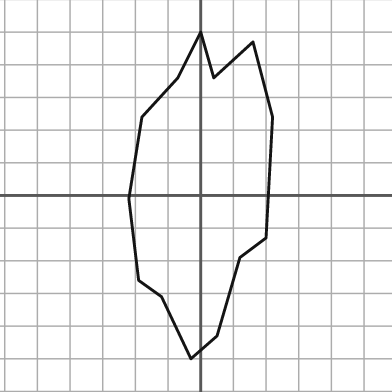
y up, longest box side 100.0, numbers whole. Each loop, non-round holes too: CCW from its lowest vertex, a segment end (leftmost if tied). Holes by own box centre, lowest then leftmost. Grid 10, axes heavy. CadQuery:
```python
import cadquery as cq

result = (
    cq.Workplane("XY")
    .moveTo(-3.0, -50.0)
    .lineTo(5.0, -43.0)
    .lineTo(12.0, -19.0)
    .lineTo(20.0, -13.0)
    .lineTo(22.0, 24.0)
    .lineTo(16.0, 47.0)
    .lineTo(4.0, 36.0)
    .lineTo(0.0, 50.0)
    .lineTo(-7.0, 36.0)
    .lineTo(-18.0, 24.0)
    .lineTo(-22.0, -1.0)
    .lineTo(-19.0, -26.0)
    .lineTo(-12.0, -31.0)
    .close()
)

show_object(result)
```